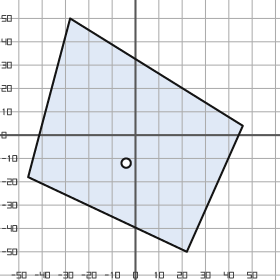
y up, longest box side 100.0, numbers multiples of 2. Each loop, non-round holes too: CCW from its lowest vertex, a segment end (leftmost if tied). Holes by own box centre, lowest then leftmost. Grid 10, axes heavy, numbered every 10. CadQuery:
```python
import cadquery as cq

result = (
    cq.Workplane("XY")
    .moveTo(22.0, -50.0)
    .lineTo(46.0, 4.0)
    .lineTo(-28.0, 50.0)
    .lineTo(-46.0, -18.0)
    .close()
    .moveTo(-4.0, -12.0)
    .circle(2.0)
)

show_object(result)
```